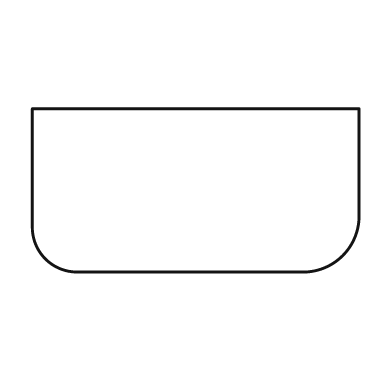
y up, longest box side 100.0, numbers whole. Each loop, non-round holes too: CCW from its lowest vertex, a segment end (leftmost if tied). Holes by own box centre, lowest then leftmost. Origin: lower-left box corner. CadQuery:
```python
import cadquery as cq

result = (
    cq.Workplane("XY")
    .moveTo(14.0, 0.0)
    .lineTo(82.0, 0.0)
    .threePointArc((95.0, 5.0), (100.0, 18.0))
    .lineTo(100.0, 50.0)
    .lineTo(0.0, 50.0)
    .lineTo(0.0, 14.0)
    .threePointArc((4.0, 4.0), (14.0, 0.0))
    .close()
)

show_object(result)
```